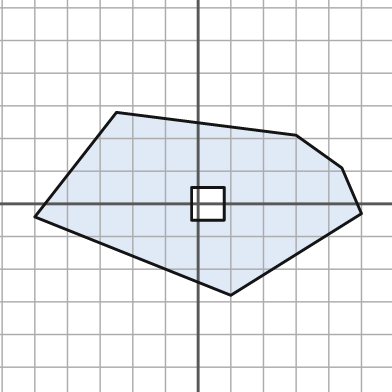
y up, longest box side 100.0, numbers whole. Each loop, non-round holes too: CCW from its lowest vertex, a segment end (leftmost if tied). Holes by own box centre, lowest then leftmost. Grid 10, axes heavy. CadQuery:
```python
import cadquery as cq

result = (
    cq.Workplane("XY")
    .moveTo(10.0, -28.0)
    .lineTo(50.0, -3.0)
    .lineTo(44.0, 11.0)
    .lineTo(30.0, 21.0)
    .lineTo(-25.0, 28.0)
    .lineTo(-50.0, -4.0)
    .close()
    .moveTo(-2.0, -5.0)
    .lineTo(8.0, -5.0)
    .lineTo(8.0, 5.0)
    .lineTo(-2.0, 5.0)
    .close()
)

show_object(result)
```